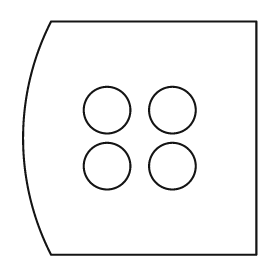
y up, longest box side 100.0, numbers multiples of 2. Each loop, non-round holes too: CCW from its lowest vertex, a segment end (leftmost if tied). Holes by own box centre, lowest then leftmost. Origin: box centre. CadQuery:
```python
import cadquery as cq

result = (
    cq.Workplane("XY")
    .moveTo(-38.0, -50.0)
    .lineTo(50.0, -50.0)
    .lineTo(50.0, 50.0)
    .lineTo(-38.0, 50.0)
    .threePointArc((-50.0, 0.0), (-38.0, -50.0))
    .close()
    .moveTo(-14.0, -12.0)
    .circle(10.0)
    .moveTo(14.0, -12.0)
    .circle(10.0)
    .moveTo(-14.0, 12.0)
    .circle(10.0)
    .moveTo(14.0, 12.0)
    .circle(10.0)
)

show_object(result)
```